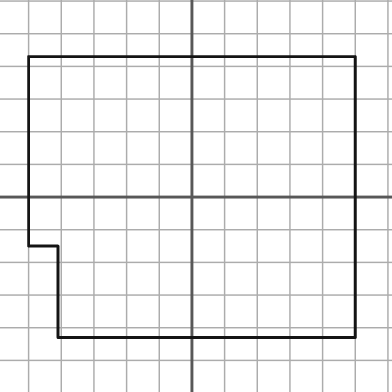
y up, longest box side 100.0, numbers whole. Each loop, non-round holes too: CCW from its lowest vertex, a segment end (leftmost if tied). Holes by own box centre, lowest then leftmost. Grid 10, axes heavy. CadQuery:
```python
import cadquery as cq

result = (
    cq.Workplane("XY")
    .moveTo(-41.0, -43.0)
    .lineTo(50.0, -43.0)
    .lineTo(50.0, 43.0)
    .lineTo(-50.0, 43.0)
    .lineTo(-50.0, -15.0)
    .lineTo(-41.0, -15.0)
    .close()
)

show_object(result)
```